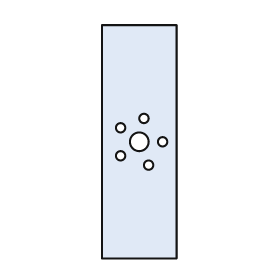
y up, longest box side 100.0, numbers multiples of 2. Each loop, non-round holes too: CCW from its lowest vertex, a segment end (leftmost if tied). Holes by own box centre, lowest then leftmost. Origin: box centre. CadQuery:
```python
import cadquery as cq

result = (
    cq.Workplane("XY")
    .moveTo(-16.0, -50.0)
    .lineTo(16.0, -50.0)
    .lineTo(16.0, 50.0)
    .lineTo(-16.0, 50.0)
    .close()
    .moveTo(4.0, -10.0)
    .circle(2.0)
    .moveTo(-8.0, -6.0)
    .circle(2.0)
    .moveTo(0.0, 0.0)
    .circle(4.0)
    .moveTo(10.0, 0.0)
    .circle(2.0)
    .moveTo(-8.0, 6.0)
    .circle(2.0)
    .moveTo(2.0, 10.0)
    .circle(2.0)
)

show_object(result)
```